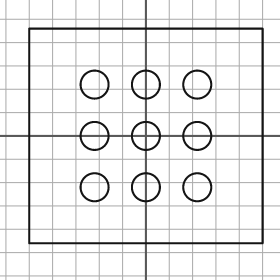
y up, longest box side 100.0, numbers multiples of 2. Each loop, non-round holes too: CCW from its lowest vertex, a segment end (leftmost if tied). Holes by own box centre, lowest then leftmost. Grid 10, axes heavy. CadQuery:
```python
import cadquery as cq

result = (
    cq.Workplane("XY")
    .moveTo(-50.0, -46.0)
    .lineTo(50.0, -46.0)
    .lineTo(50.0, 46.0)
    .lineTo(-50.0, 46.0)
    .close()
    .moveTo(-22.0, -22.0)
    .circle(6.0)
    .moveTo(0.0, -22.0)
    .circle(6.0)
    .moveTo(22.0, -22.0)
    .circle(6.0)
    .moveTo(-22.0, 0.0)
    .circle(6.0)
    .moveTo(0.0, 0.0)
    .circle(6.0)
    .moveTo(22.0, 0.0)
    .circle(6.0)
    .moveTo(-22.0, 22.0)
    .circle(6.0)
    .moveTo(0.0, 22.0)
    .circle(6.0)
    .moveTo(22.0, 22.0)
    .circle(6.0)
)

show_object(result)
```